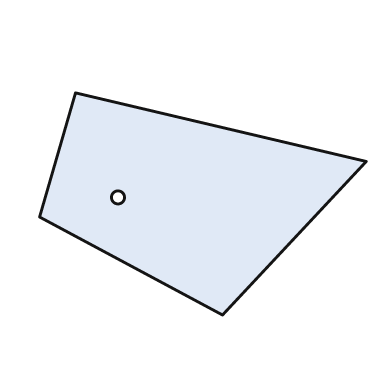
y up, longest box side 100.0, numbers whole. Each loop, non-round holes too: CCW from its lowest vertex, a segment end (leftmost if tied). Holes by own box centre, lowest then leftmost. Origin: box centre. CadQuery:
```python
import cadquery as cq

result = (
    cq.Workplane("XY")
    .moveTo(6.0, -34.0)
    .lineTo(50.0, 13.0)
    .lineTo(-39.0, 34.0)
    .lineTo(-50.0, -4.0)
    .close()
    .moveTo(-26.0, 2.0)
    .circle(2.0)
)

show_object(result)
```